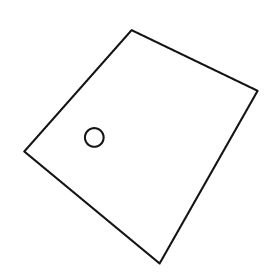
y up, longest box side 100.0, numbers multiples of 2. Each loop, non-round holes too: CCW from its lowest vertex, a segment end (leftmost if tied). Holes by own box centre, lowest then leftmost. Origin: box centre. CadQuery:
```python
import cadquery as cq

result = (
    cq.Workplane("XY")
    .moveTo(8.0, -50.0)
    .lineTo(50.0, 24.0)
    .lineTo(-4.0, 50.0)
    .lineTo(-50.0, -2.0)
    .close()
    .moveTo(-20.0, 4.0)
    .circle(4.0)
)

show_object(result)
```